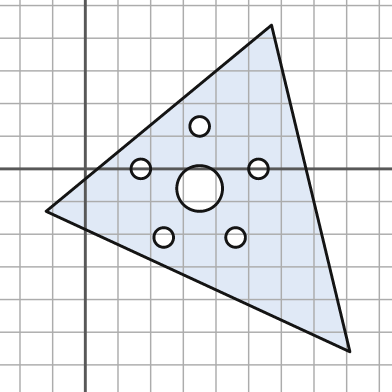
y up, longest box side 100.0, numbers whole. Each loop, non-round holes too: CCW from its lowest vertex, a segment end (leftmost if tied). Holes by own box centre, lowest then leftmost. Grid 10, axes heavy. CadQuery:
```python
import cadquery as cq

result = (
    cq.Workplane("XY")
    .moveTo(81.0, -56.0)
    .lineTo(57.0, 44.0)
    .lineTo(-12.0, -13.0)
    .close()
    .moveTo(24.0, -21.0)
    .circle(3.0)
    .moveTo(46.0, -21.0)
    .circle(3.0)
    .moveTo(35.0, -6.0)
    .circle(7.0)
    .moveTo(17.0, 0.0)
    .circle(3.0)
    .moveTo(53.0, 0.0)
    .circle(3.0)
    .moveTo(35.0, 13.0)
    .circle(3.0)
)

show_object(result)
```